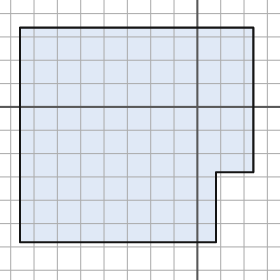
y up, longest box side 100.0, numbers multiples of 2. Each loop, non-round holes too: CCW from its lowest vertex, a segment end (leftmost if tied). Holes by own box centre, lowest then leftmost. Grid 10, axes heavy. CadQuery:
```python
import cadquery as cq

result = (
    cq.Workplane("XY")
    .moveTo(-76.0, -58.0)
    .lineTo(8.0, -58.0)
    .lineTo(8.0, -28.0)
    .lineTo(24.0, -28.0)
    .lineTo(24.0, 34.0)
    .lineTo(-76.0, 34.0)
    .close()
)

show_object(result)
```